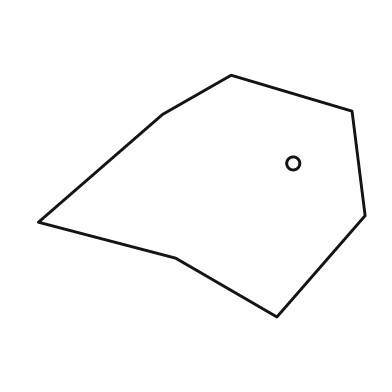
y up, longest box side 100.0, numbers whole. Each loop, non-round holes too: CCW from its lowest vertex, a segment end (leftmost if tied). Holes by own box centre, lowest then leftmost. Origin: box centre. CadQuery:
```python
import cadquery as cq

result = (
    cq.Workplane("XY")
    .moveTo(23.0, -37.0)
    .lineTo(50.0, -6.0)
    .lineTo(46.0, 26.0)
    .lineTo(9.0, 37.0)
    .lineTo(-12.0, 25.0)
    .lineTo(-50.0, -8.0)
    .lineTo(-8.0, -19.0)
    .close()
    .moveTo(28.0, 10.0)
    .circle(2.0)
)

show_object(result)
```